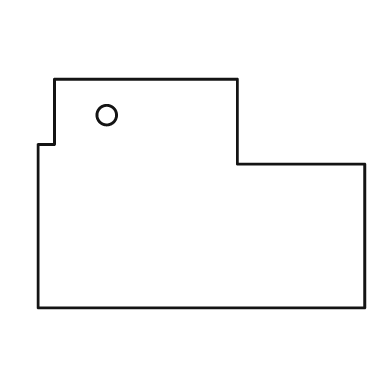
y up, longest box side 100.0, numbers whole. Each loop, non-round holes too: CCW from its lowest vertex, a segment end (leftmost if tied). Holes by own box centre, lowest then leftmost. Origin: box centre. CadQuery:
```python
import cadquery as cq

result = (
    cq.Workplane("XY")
    .moveTo(-50.0, -35.0)
    .lineTo(50.0, -35.0)
    .lineTo(50.0, 9.0)
    .lineTo(11.0, 9.0)
    .lineTo(11.0, 35.0)
    .lineTo(-45.0, 35.0)
    .lineTo(-45.0, 15.0)
    .lineTo(-50.0, 15.0)
    .close()
    .moveTo(-29.0, 24.0)
    .circle(3.0)
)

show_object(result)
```